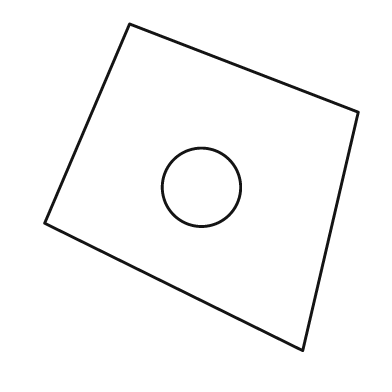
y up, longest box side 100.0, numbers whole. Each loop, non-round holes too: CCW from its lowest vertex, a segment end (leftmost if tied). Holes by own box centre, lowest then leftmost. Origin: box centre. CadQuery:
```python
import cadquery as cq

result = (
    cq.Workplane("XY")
    .moveTo(31.0, -50.0)
    .lineTo(48.0, 23.0)
    .lineTo(-22.0, 50.0)
    .lineTo(-48.0, -11.0)
    .close()
    .moveTo(0.0, 0.0)
    .circle(12.0)
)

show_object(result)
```